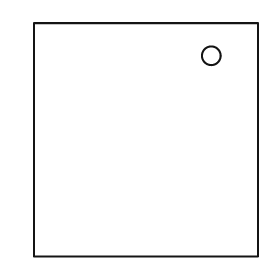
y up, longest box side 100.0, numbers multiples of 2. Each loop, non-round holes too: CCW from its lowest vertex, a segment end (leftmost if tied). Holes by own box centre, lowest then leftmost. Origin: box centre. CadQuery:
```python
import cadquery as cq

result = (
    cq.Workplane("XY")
    .moveTo(-48.0, -50.0)
    .lineTo(48.0, -50.0)
    .lineTo(48.0, 50.0)
    .lineTo(-48.0, 50.0)
    .close()
    .moveTo(28.0, 36.0)
    .circle(4.0)
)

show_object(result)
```